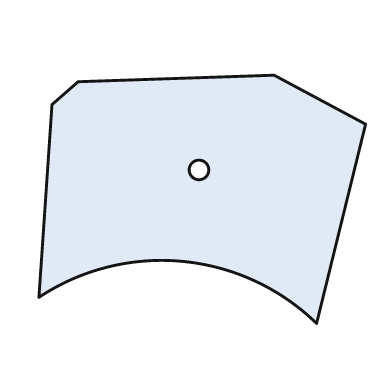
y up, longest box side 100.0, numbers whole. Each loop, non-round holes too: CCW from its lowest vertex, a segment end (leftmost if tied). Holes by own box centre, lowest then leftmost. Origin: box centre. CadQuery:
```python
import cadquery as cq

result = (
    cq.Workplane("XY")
    .moveTo(35.0, -38.0)
    .lineTo(50.0, 23.0)
    .lineTo(22.0, 38.0)
    .lineTo(-38.0, 36.0)
    .lineTo(-46.0, 29.0)
    .lineTo(-50.0, -30.0)
    .threePointArc((-6.0, -19.0), (35.0, -38.0))
    .close()
    .moveTo(-1.0, 9.0)
    .circle(3.0)
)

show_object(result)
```